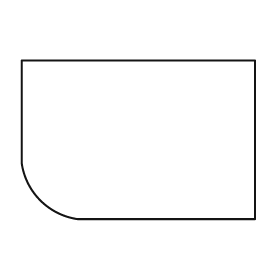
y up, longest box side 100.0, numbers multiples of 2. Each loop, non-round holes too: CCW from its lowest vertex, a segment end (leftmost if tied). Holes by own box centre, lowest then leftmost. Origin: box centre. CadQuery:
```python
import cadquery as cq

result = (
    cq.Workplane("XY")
    .moveTo(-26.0, -34.0)
    .lineTo(50.0, -34.0)
    .lineTo(50.0, 34.0)
    .lineTo(-50.0, 34.0)
    .lineTo(-50.0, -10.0)
    .threePointArc((-42.0, -26.0), (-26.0, -34.0))
    .close()
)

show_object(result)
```